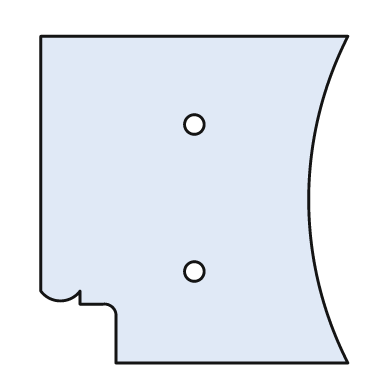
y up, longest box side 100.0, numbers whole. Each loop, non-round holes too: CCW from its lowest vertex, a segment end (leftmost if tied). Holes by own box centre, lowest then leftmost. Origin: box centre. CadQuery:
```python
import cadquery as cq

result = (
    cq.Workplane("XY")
    .moveTo(-24.0, -50.0)
    .lineTo(47.0, -50.0)
    .threePointArc((35.0, 0.0), (47.0, 50.0))
    .lineTo(-47.0, 50.0)
    .lineTo(-47.0, -28.0)
    .threePointArc((-41.0, -31.0), (-35.0, -28.0))
    .lineTo(-35.0, -32.0)
    .lineTo(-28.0, -32.0)
    .threePointArc((-25.0, -33.0), (-24.0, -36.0))
    .close()
    .moveTo(0.0, -22.0)
    .circle(3.0)
    .moveTo(0.0, 23.0)
    .circle(3.0)
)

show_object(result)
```